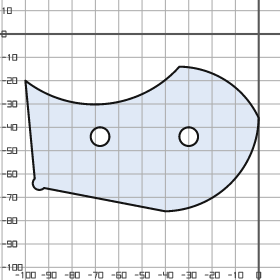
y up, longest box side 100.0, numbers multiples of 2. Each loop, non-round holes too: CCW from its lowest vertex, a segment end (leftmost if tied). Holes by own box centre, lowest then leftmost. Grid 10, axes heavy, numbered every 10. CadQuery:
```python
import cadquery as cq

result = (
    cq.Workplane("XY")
    .moveTo(-40.0, -76.0)
    .threePointArc((-12.0, -64.0), (0.0, -36.0))
    .threePointArc((-14.0, -20.0), (-34.0, -14.0))
    .threePointArc((-66.0, -30.0), (-100.0, -20.0))
    .lineTo(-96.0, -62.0)
    .threePointArc((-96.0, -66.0), (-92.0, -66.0))
    .close()
    .moveTo(-68.0, -44.0)
    .circle(4.0)
    .moveTo(-30.0, -44.0)
    .circle(4.0)
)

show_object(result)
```